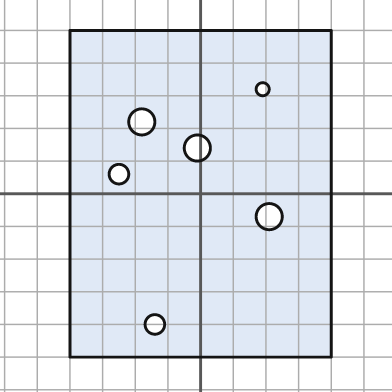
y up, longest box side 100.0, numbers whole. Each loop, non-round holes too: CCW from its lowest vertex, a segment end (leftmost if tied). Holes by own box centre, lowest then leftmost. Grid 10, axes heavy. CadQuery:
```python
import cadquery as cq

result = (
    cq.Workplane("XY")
    .moveTo(-40.0, -50.0)
    .lineTo(40.0, -50.0)
    .lineTo(40.0, 50.0)
    .lineTo(-40.0, 50.0)
    .close()
    .moveTo(-14.0, -40.0)
    .circle(3.0)
    .moveTo(21.0, -7.0)
    .circle(4.0)
    .moveTo(-25.0, 6.0)
    .circle(3.0)
    .moveTo(-1.0, 14.0)
    .circle(4.0)
    .moveTo(-18.0, 22.0)
    .circle(4.0)
    .moveTo(19.0, 32.0)
    .circle(2.0)
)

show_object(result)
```